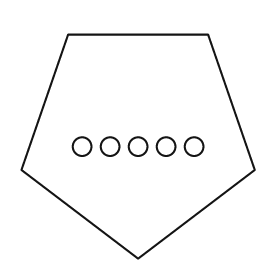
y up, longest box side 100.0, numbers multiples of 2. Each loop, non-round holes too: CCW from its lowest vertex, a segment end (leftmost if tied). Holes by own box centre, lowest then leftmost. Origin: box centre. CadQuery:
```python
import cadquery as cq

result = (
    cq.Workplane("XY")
    .moveTo(0.0, -48.0)
    .lineTo(50.0, -10.0)
    .lineTo(30.0, 48.0)
    .lineTo(-30.0, 48.0)
    .lineTo(-50.0, -10.0)
    .close()
    .moveTo(-24.0, 0.0)
    .circle(4.0)
    .moveTo(-12.0, 0.0)
    .circle(4.0)
    .moveTo(0.0, 0.0)
    .circle(4.0)
    .moveTo(12.0, 0.0)
    .circle(4.0)
    .moveTo(24.0, 0.0)
    .circle(4.0)
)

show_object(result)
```